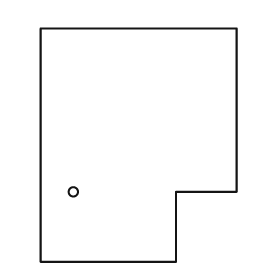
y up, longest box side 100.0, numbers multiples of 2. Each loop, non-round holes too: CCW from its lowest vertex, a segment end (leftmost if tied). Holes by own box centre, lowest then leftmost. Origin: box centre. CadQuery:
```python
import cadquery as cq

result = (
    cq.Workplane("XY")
    .moveTo(-42.0, -50.0)
    .lineTo(16.0, -50.0)
    .lineTo(16.0, -20.0)
    .lineTo(42.0, -20.0)
    .lineTo(42.0, 50.0)
    .lineTo(-42.0, 50.0)
    .close()
    .moveTo(-28.0, -20.0)
    .circle(2.0)
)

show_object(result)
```